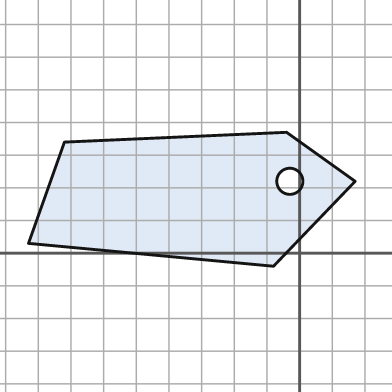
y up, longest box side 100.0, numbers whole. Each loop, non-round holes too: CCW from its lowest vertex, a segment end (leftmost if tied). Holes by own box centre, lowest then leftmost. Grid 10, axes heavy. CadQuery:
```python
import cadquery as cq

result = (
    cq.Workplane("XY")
    .moveTo(-8.0, -4.0)
    .lineTo(17.0, 22.0)
    .lineTo(-4.0, 37.0)
    .lineTo(-72.0, 34.0)
    .lineTo(-83.0, 3.0)
    .close()
    .moveTo(-3.0, 22.0)
    .circle(4.0)
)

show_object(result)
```